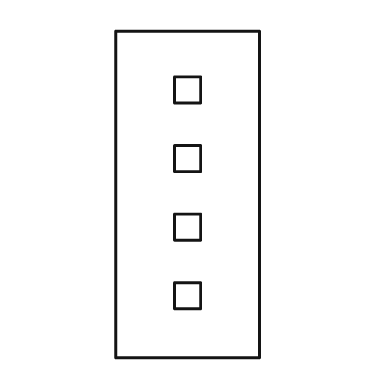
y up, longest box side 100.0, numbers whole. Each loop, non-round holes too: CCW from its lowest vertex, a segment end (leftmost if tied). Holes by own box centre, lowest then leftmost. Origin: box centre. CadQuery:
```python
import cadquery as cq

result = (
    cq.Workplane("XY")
    .moveTo(-22.0, -50.0)
    .lineTo(22.0, -50.0)
    .lineTo(22.0, 50.0)
    .lineTo(-22.0, 50.0)
    .close()
    .moveTo(-4.0, -35.0)
    .lineTo(4.0, -35.0)
    .lineTo(4.0, -27.0)
    .lineTo(-4.0, -27.0)
    .close()
    .moveTo(-4.0, -14.0)
    .lineTo(4.0, -14.0)
    .lineTo(4.0, -6.0)
    .lineTo(-4.0, -6.0)
    .close()
    .moveTo(-4.0, 7.0)
    .lineTo(4.0, 7.0)
    .lineTo(4.0, 15.0)
    .lineTo(-4.0, 15.0)
    .close()
    .moveTo(-4.0, 28.0)
    .lineTo(4.0, 28.0)
    .lineTo(4.0, 36.0)
    .lineTo(-4.0, 36.0)
    .close()
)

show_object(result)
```